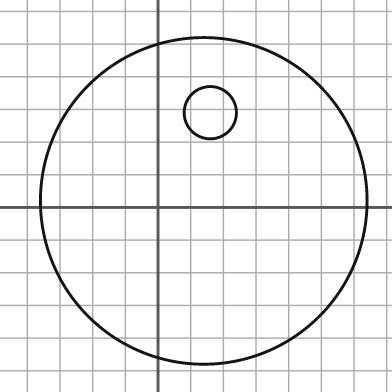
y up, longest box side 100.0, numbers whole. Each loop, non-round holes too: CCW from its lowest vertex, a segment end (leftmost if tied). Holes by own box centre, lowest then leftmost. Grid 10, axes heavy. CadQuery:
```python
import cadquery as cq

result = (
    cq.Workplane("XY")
    .moveTo(14.0, 2.0)
    .circle(50.0)
    .moveTo(16.0, 29.0)
    .circle(8.0)
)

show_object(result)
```